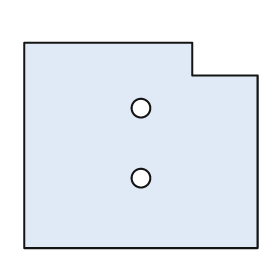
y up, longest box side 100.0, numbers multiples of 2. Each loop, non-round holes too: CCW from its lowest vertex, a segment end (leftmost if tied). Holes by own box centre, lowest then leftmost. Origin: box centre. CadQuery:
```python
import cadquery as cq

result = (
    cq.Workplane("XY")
    .moveTo(-50.0, -44.0)
    .lineTo(50.0, -44.0)
    .lineTo(50.0, 30.0)
    .lineTo(22.0, 30.0)
    .lineTo(22.0, 44.0)
    .lineTo(-50.0, 44.0)
    .close()
    .moveTo(0.0, -14.0)
    .circle(4.0)
    .moveTo(0.0, 16.0)
    .circle(4.0)
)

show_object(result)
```